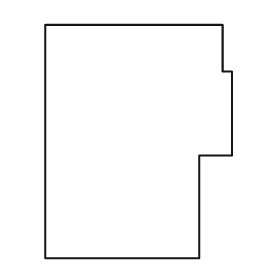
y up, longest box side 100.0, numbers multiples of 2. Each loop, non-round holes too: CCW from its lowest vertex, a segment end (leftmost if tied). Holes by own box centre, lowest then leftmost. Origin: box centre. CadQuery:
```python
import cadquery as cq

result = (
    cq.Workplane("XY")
    .moveTo(-40.0, -50.0)
    .lineTo(26.0, -50.0)
    .lineTo(26.0, -6.0)
    .lineTo(40.0, -6.0)
    .lineTo(40.0, 30.0)
    .lineTo(36.0, 30.0)
    .lineTo(36.0, 50.0)
    .lineTo(-40.0, 50.0)
    .close()
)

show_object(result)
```